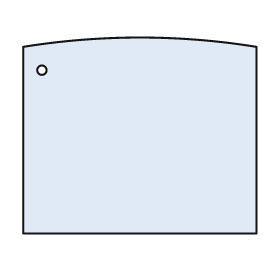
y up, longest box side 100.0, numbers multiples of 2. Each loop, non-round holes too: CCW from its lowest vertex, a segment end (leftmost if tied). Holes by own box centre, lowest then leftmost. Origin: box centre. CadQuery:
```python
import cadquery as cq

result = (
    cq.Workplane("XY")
    .moveTo(-50.0, -42.0)
    .lineTo(50.0, -42.0)
    .lineTo(50.0, 38.0)
    .threePointArc((0.0, 42.0), (-50.0, 38.0))
    .close()
    .moveTo(-42.0, 28.0)
    .circle(2.0)
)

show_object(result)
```